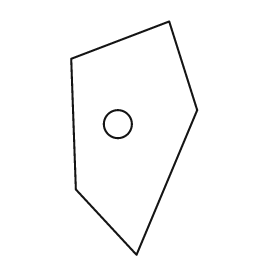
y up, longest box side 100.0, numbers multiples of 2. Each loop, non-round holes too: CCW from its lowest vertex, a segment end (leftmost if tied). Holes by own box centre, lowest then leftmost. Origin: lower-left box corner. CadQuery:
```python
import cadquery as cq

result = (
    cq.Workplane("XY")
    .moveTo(28.0, 0.0)
    .lineTo(54.0, 62.0)
    .lineTo(42.0, 100.0)
    .lineTo(0.0, 84.0)
    .lineTo(2.0, 28.0)
    .close()
    .moveTo(20.0, 56.0)
    .circle(6.0)
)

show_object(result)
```